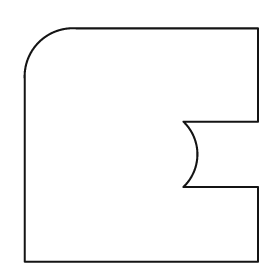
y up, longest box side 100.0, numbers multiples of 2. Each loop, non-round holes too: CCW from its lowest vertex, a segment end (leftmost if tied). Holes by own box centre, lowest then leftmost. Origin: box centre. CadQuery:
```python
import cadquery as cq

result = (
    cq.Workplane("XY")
    .moveTo(-50.0, -50.0)
    .lineTo(50.0, -50.0)
    .lineTo(50.0, -18.0)
    .lineTo(18.0, -18.0)
    .threePointArc((24.0, -4.0), (18.0, 10.0))
    .lineTo(50.0, 10.0)
    .lineTo(50.0, 50.0)
    .lineTo(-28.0, 50.0)
    .threePointArc((-44.0, 44.0), (-50.0, 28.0))
    .close()
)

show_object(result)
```